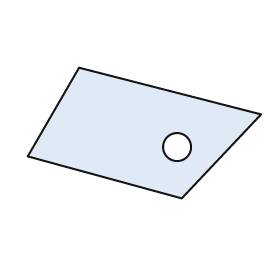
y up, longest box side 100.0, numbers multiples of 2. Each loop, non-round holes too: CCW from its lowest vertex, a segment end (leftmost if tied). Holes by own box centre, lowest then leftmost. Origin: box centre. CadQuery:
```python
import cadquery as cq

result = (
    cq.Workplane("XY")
    .moveTo(16.0, -28.0)
    .lineTo(50.0, 8.0)
    .lineTo(-28.0, 28.0)
    .lineTo(-50.0, -10.0)
    .close()
    .moveTo(14.0, -6.0)
    .circle(6.0)
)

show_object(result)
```